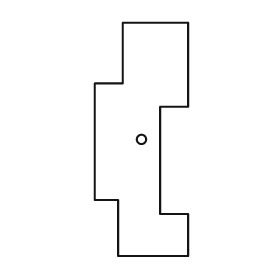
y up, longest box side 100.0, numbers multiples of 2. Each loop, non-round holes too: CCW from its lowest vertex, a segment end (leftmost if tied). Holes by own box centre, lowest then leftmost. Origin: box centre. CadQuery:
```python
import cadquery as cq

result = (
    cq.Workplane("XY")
    .moveTo(-10.0, -50.0)
    .lineTo(20.0, -50.0)
    .lineTo(20.0, -32.0)
    .lineTo(8.0, -32.0)
    .lineTo(8.0, 14.0)
    .lineTo(20.0, 14.0)
    .lineTo(20.0, 50.0)
    .lineTo(-8.0, 50.0)
    .lineTo(-8.0, 24.0)
    .lineTo(-20.0, 24.0)
    .lineTo(-20.0, -26.0)
    .lineTo(-10.0, -26.0)
    .close()
    .moveTo(0.0, 0.0)
    .circle(2.0)
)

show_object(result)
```